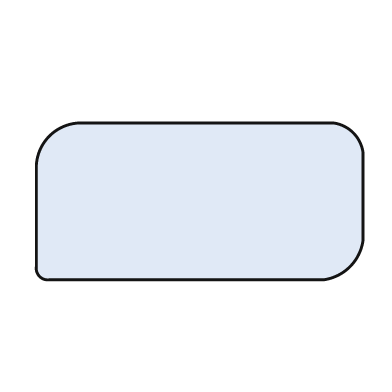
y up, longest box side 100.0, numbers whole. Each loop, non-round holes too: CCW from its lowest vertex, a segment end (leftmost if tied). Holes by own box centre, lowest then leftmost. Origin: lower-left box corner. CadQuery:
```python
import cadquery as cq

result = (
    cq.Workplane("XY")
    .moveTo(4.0, 0.0)
    .lineTo(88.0, 0.0)
    .threePointArc((96.0, 4.0), (100.0, 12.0))
    .lineTo(100.0, 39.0)
    .threePointArc((97.0, 45.0), (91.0, 48.0))
    .lineTo(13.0, 48.0)
    .threePointArc((4.0, 44.0), (0.0, 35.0))
    .lineTo(0.0, 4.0)
    .threePointArc((1.0, 1.0), (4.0, 0.0))
    .close()
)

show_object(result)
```